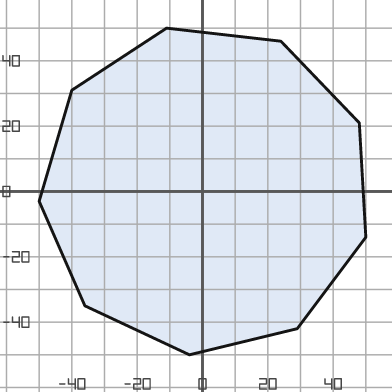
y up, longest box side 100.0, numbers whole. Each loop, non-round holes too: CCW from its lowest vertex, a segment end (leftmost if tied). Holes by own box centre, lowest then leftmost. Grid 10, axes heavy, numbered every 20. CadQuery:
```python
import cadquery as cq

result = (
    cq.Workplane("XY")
    .moveTo(-4.0, -50.0)
    .lineTo(29.0, -42.0)
    .lineTo(50.0, -14.0)
    .lineTo(48.0, 21.0)
    .lineTo(24.0, 46.0)
    .lineTo(-11.0, 50.0)
    .lineTo(-40.0, 31.0)
    .lineTo(-50.0, -3.0)
    .lineTo(-36.0, -35.0)
    .close()
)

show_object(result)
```